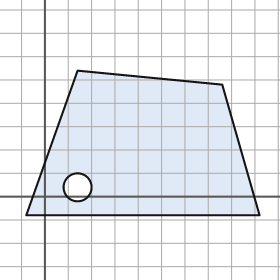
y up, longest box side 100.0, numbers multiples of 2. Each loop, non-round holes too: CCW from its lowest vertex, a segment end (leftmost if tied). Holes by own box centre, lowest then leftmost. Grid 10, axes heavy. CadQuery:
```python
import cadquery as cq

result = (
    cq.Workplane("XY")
    .moveTo(-8.0, -8.0)
    .lineTo(92.0, -8.0)
    .lineTo(76.0, 48.0)
    .lineTo(14.0, 54.0)
    .close()
    .moveTo(14.0, 4.0)
    .circle(6.0)
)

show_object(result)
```